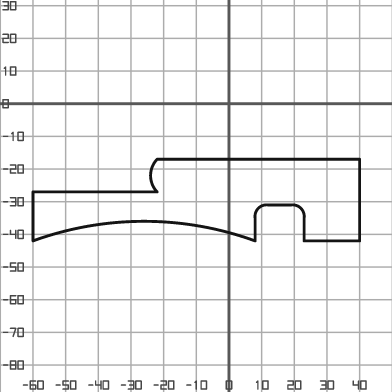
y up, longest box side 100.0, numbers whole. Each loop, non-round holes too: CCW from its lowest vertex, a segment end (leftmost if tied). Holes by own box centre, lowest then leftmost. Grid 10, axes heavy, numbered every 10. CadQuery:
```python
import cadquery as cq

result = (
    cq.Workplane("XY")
    .moveTo(-60.0, -42.0)
    .threePointArc((-26.0, -36.0), (8.0, -42.0))
    .lineTo(8.0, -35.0)
    .threePointArc((9.0, -32.0), (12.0, -31.0))
    .lineTo(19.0, -31.0)
    .threePointArc((22.0, -32.0), (23.0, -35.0))
    .lineTo(23.0, -42.0)
    .lineTo(40.0, -42.0)
    .lineTo(40.0, -17.0)
    .lineTo(-22.0, -17.0)
    .threePointArc((-24.0, -22.0), (-22.0, -27.0))
    .lineTo(-60.0, -27.0)
    .close()
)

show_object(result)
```